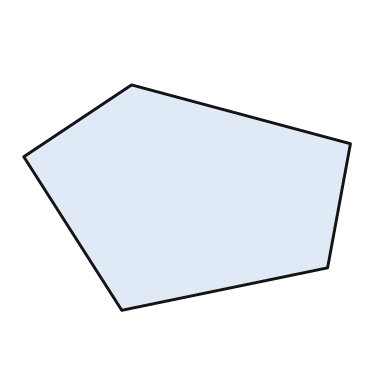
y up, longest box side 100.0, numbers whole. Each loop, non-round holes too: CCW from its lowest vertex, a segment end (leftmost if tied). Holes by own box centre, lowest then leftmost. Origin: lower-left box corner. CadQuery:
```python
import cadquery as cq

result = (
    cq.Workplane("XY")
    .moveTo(30.0, 0.0)
    .lineTo(93.0, 13.0)
    .lineTo(100.0, 51.0)
    .lineTo(33.0, 69.0)
    .lineTo(0.0, 47.0)
    .close()
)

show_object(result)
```